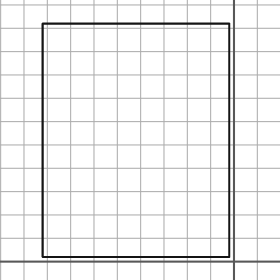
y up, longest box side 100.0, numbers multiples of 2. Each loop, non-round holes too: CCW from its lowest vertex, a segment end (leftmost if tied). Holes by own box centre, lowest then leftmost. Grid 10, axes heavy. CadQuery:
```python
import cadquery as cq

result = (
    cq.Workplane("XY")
    .moveTo(-82.0, 2.0)
    .lineTo(-2.0, 2.0)
    .lineTo(-2.0, 102.0)
    .lineTo(-82.0, 102.0)
    .close()
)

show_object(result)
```